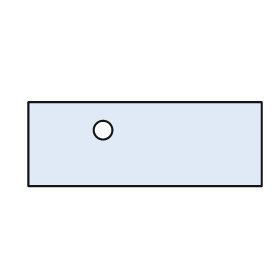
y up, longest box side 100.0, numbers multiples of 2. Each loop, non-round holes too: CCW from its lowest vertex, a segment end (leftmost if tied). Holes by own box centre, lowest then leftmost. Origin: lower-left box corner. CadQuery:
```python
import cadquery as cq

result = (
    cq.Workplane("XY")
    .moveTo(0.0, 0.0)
    .lineTo(100.0, 0.0)
    .lineTo(100.0, 36.0)
    .lineTo(0.0, 36.0)
    .close()
    .moveTo(32.0, 24.0)
    .circle(4.0)
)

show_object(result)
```